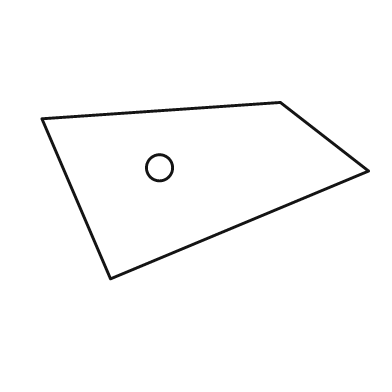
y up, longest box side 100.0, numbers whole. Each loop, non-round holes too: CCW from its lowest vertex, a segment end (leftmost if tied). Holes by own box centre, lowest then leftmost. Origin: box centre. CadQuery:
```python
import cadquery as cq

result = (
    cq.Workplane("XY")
    .moveTo(-29.0, -27.0)
    .lineTo(50.0, 6.0)
    .lineTo(23.0, 27.0)
    .lineTo(-50.0, 22.0)
    .close()
    .moveTo(-14.0, 7.0)
    .circle(4.0)
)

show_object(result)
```